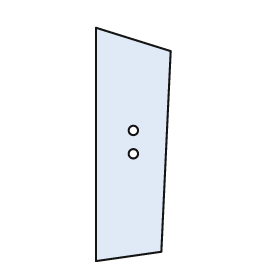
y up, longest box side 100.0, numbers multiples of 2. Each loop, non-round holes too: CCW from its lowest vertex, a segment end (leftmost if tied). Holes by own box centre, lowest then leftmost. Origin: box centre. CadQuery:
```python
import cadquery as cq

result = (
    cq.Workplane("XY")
    .moveTo(-16.0, -50.0)
    .lineTo(12.0, -46.0)
    .lineTo(16.0, 40.0)
    .lineTo(-16.0, 50.0)
    .close()
    .moveTo(0.0, -4.0)
    .circle(2.0)
    .moveTo(0.0, 6.0)
    .circle(2.0)
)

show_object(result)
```